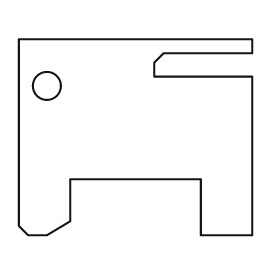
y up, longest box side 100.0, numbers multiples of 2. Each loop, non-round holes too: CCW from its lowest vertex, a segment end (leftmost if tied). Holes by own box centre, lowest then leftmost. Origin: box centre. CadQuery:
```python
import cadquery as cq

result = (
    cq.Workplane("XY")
    .moveTo(-46.0, -42.0)
    .lineTo(-38.0, -42.0)
    .lineTo(-28.0, -36.0)
    .lineTo(-28.0, -18.0)
    .lineTo(28.0, -18.0)
    .lineTo(28.0, -42.0)
    .lineTo(50.0, -42.0)
    .lineTo(50.0, 26.0)
    .lineTo(8.0, 26.0)
    .lineTo(8.0, 32.0)
    .lineTo(12.0, 36.0)
    .lineTo(50.0, 36.0)
    .lineTo(50.0, 42.0)
    .lineTo(-50.0, 42.0)
    .lineTo(-50.0, -38.0)
    .close()
    .moveTo(-38.0, 22.0)
    .circle(6.0)
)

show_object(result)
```